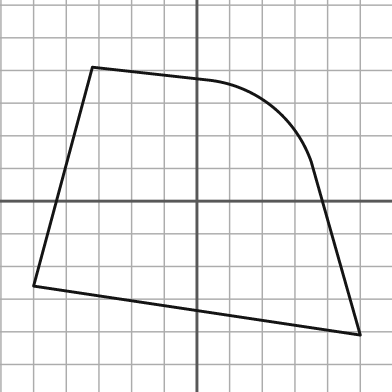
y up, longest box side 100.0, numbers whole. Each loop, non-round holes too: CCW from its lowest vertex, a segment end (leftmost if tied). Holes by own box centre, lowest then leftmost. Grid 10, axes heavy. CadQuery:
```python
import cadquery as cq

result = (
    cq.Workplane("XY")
    .moveTo(50.0, -41.0)
    .lineTo(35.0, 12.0)
    .threePointArc((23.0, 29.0), (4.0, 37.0))
    .lineTo(-32.0, 41.0)
    .lineTo(-50.0, -26.0)
    .close()
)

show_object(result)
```